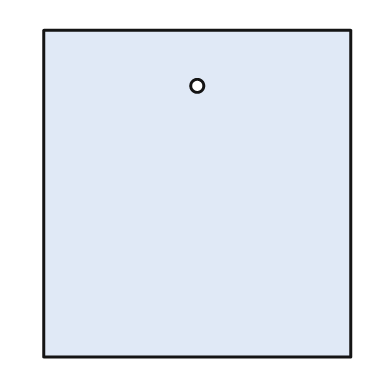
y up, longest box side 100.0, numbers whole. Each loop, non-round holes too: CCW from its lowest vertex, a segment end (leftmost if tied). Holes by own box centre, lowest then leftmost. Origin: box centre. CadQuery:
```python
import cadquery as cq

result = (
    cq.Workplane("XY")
    .moveTo(-47.0, -50.0)
    .lineTo(47.0, -50.0)
    .lineTo(47.0, 50.0)
    .lineTo(-47.0, 50.0)
    .close()
    .moveTo(0.0, 33.0)
    .circle(2.0)
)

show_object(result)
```